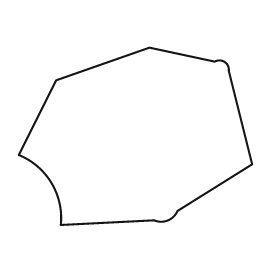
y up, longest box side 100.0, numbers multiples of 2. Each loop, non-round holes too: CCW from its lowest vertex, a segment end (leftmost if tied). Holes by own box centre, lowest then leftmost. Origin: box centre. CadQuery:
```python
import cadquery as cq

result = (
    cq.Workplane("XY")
    .moveTo(-32.0, -38.0)
    .lineTo(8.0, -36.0)
    .threePointArc((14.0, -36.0), (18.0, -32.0))
    .lineTo(50.0, -12.0)
    .lineTo(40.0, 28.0)
    .threePointArc((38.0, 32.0), (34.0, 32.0))
    .lineTo(6.0, 38.0)
    .lineTo(-34.0, 24.0)
    .lineTo(-50.0, -8.0)
    .threePointArc((-36.0, -20.0), (-32.0, -38.0))
    .close()
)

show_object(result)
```